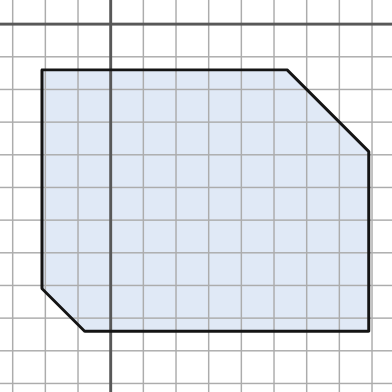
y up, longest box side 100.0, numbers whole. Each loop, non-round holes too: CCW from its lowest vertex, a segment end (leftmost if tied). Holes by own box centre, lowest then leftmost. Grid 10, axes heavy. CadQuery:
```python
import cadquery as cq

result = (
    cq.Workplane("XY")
    .moveTo(-8.0, -94.0)
    .lineTo(79.0, -94.0)
    .lineTo(79.0, -39.0)
    .lineTo(54.0, -14.0)
    .lineTo(-21.0, -14.0)
    .lineTo(-21.0, -81.0)
    .close()
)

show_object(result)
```